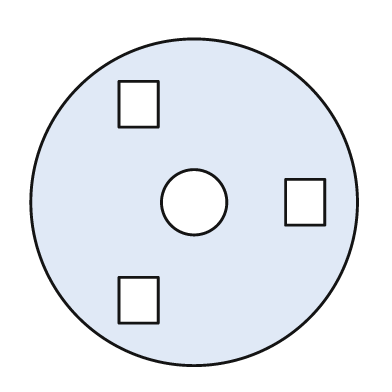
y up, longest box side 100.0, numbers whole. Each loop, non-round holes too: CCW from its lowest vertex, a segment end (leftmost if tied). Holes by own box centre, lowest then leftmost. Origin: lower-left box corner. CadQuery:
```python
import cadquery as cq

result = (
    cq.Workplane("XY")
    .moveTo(50.0, 50.0)
    .circle(50.0)
    .moveTo(27.0, 13.0)
    .lineTo(39.0, 13.0)
    .lineTo(39.0, 27.0)
    .lineTo(27.0, 27.0)
    .close()
    .moveTo(50.0, 50.0)
    .circle(10.0)
    .moveTo(78.0, 43.0)
    .lineTo(90.0, 43.0)
    .lineTo(90.0, 57.0)
    .lineTo(78.0, 57.0)
    .close()
    .moveTo(27.0, 73.0)
    .lineTo(39.0, 73.0)
    .lineTo(39.0, 87.0)
    .lineTo(27.0, 87.0)
    .close()
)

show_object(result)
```